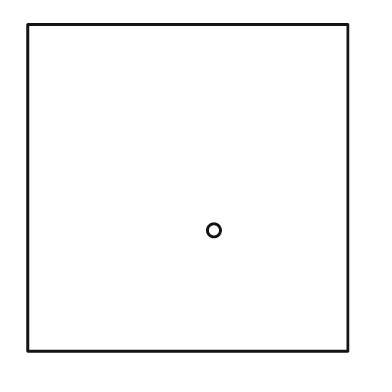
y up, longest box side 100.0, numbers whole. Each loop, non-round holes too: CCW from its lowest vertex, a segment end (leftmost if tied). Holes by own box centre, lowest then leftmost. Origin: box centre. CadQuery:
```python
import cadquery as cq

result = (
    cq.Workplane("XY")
    .moveTo(-49.0, -50.0)
    .lineTo(49.0, -50.0)
    .lineTo(49.0, 50.0)
    .lineTo(-49.0, 50.0)
    .close()
    .moveTo(8.0, -13.0)
    .circle(2.0)
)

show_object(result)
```